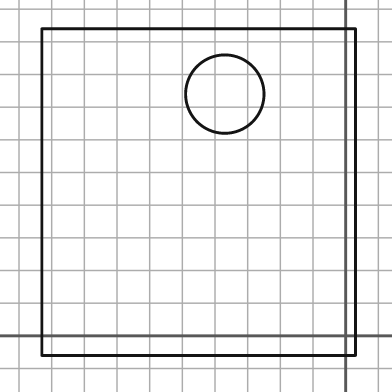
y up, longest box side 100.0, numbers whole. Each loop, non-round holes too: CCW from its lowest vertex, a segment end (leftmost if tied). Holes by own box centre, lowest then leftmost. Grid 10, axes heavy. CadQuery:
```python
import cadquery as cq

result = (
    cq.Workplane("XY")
    .moveTo(-93.0, -6.0)
    .lineTo(3.0, -6.0)
    .lineTo(3.0, 94.0)
    .lineTo(-93.0, 94.0)
    .close()
    .moveTo(-37.0, 74.0)
    .circle(12.0)
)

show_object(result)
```